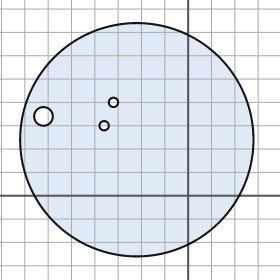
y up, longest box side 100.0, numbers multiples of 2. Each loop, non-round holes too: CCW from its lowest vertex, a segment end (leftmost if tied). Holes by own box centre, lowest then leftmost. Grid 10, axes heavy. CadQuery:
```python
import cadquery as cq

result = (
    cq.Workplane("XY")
    .moveTo(-22.0, 24.0)
    .circle(50.0)
    .moveTo(-36.0, 30.0)
    .circle(2.0)
    .moveTo(-62.0, 34.0)
    .circle(4.0)
    .moveTo(-32.0, 40.0)
    .circle(2.0)
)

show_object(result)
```